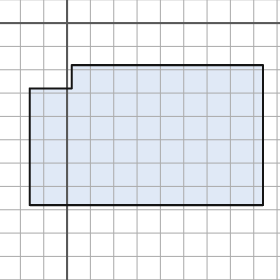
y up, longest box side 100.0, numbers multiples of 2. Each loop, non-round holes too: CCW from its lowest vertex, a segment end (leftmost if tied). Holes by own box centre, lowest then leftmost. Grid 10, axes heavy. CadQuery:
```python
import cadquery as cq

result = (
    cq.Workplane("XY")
    .moveTo(-16.0, -78.0)
    .lineTo(84.0, -78.0)
    .lineTo(84.0, -18.0)
    .lineTo(2.0, -18.0)
    .lineTo(2.0, -28.0)
    .lineTo(-16.0, -28.0)
    .close()
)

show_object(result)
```